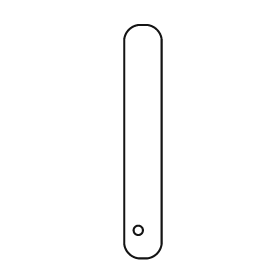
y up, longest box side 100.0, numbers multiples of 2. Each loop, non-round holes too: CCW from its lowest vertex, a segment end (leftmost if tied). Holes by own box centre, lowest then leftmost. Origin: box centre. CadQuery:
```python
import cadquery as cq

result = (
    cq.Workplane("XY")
    .moveTo(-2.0, -50.0)
    .lineTo(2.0, -50.0)
    .threePointArc((6.0, -48.0), (8.0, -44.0))
    .lineTo(8.0, 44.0)
    .threePointArc((6.0, 48.0), (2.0, 50.0))
    .lineTo(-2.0, 50.0)
    .threePointArc((-6.0, 48.0), (-8.0, 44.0))
    .lineTo(-8.0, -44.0)
    .threePointArc((-6.0, -48.0), (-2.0, -50.0))
    .close()
    .moveTo(-2.0, -38.0)
    .circle(2.0)
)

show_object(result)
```